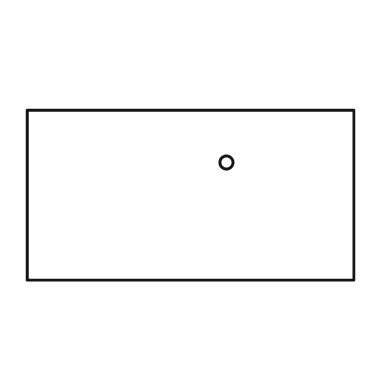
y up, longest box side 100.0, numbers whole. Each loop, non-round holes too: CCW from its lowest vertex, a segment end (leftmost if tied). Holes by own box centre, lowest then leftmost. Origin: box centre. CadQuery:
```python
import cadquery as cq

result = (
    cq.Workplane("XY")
    .moveTo(-50.0, -26.0)
    .lineTo(50.0, -26.0)
    .lineTo(50.0, 26.0)
    .lineTo(-50.0, 26.0)
    .close()
    .moveTo(11.0, 10.0)
    .circle(2.0)
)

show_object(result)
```